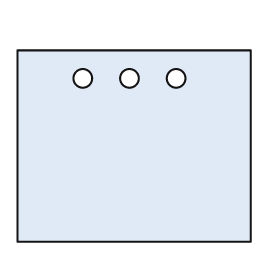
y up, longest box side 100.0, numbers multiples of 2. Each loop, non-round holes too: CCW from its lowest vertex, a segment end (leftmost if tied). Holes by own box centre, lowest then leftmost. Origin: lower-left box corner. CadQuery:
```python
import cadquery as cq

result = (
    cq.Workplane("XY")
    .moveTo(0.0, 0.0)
    .lineTo(100.0, 0.0)
    .lineTo(100.0, 82.0)
    .lineTo(0.0, 82.0)
    .close()
    .moveTo(28.0, 70.0)
    .circle(4.0)
    .moveTo(48.0, 70.0)
    .circle(4.0)
    .moveTo(68.0, 70.0)
    .circle(4.0)
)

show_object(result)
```